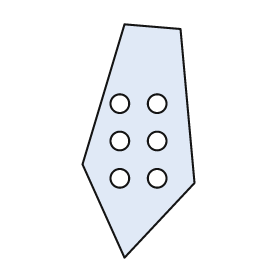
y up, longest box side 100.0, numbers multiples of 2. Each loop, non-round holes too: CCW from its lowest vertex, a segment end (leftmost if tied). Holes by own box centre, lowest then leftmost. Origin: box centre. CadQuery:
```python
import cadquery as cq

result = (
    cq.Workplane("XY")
    .moveTo(-6.0, -50.0)
    .lineTo(24.0, -18.0)
    .lineTo(18.0, 48.0)
    .lineTo(-6.0, 50.0)
    .lineTo(-24.0, -10.0)
    .close()
    .moveTo(-8.0, -16.0)
    .circle(4.0)
    .moveTo(8.0, -16.0)
    .circle(4.0)
    .moveTo(-8.0, 0.0)
    .circle(4.0)
    .moveTo(8.0, 0.0)
    .circle(4.0)
    .moveTo(-8.0, 16.0)
    .circle(4.0)
    .moveTo(8.0, 16.0)
    .circle(4.0)
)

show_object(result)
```